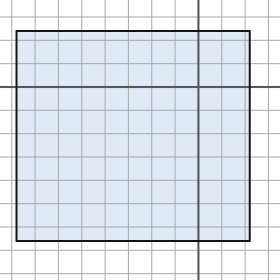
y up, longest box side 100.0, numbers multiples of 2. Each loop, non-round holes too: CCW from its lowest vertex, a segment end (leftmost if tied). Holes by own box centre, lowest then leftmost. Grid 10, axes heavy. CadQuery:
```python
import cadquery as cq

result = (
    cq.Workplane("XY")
    .moveTo(-78.0, -66.0)
    .lineTo(22.0, -66.0)
    .lineTo(22.0, 24.0)
    .lineTo(-78.0, 24.0)
    .close()
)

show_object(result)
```